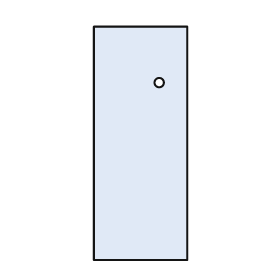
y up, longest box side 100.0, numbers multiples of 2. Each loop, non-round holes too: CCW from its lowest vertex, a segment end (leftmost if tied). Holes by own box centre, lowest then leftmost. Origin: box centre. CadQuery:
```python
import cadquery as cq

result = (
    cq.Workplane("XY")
    .moveTo(-20.0, -50.0)
    .lineTo(20.0, -50.0)
    .lineTo(20.0, 50.0)
    .lineTo(-20.0, 50.0)
    .close()
    .moveTo(8.0, 26.0)
    .circle(2.0)
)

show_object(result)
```